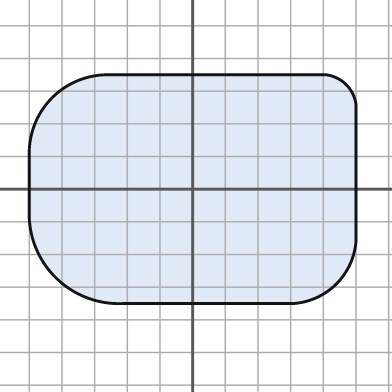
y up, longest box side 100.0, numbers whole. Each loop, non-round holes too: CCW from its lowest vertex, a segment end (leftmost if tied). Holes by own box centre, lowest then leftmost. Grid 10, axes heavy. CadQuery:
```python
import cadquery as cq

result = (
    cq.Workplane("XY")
    .moveTo(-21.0, -35.0)
    .lineTo(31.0, -35.0)
    .threePointArc((44.0, -29.0), (50.0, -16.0))
    .lineTo(50.0, 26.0)
    .threePointArc((47.0, 32.0), (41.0, 35.0))
    .lineTo(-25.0, 35.0)
    .threePointArc((-43.0, 28.0), (-50.0, 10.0))
    .lineTo(-50.0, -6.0)
    .threePointArc((-42.0, -27.0), (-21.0, -35.0))
    .close()
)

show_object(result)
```